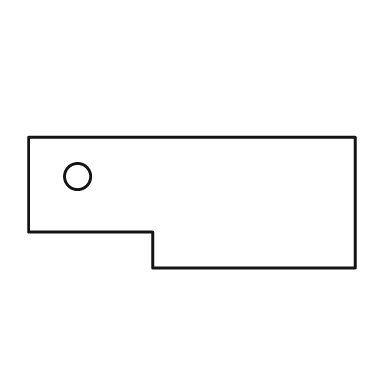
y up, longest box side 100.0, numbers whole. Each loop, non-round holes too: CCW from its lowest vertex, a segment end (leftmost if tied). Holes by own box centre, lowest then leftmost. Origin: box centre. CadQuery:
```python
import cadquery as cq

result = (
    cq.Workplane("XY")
    .moveTo(-12.0, -20.0)
    .lineTo(50.0, -20.0)
    .lineTo(50.0, 20.0)
    .lineTo(-50.0, 20.0)
    .lineTo(-50.0, -9.0)
    .lineTo(-12.0, -9.0)
    .close()
    .moveTo(-35.0, 8.0)
    .circle(4.0)
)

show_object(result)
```